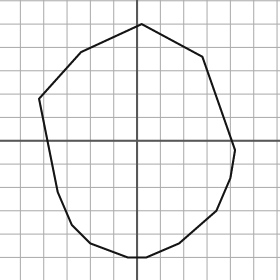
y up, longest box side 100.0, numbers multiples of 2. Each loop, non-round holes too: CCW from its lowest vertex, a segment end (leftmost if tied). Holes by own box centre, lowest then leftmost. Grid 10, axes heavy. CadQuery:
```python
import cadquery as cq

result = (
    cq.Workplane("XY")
    .moveTo(-4.0, -50.0)
    .lineTo(4.0, -50.0)
    .lineTo(18.0, -44.0)
    .lineTo(34.0, -30.0)
    .lineTo(40.0, -16.0)
    .lineTo(42.0, -4.0)
    .lineTo(28.0, 36.0)
    .lineTo(2.0, 50.0)
    .lineTo(-24.0, 38.0)
    .lineTo(-42.0, 18.0)
    .lineTo(-34.0, -22.0)
    .lineTo(-28.0, -36.0)
    .lineTo(-20.0, -44.0)
    .close()
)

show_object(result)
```